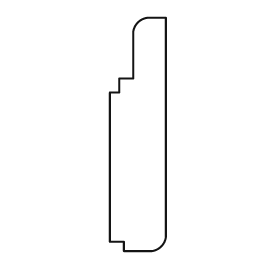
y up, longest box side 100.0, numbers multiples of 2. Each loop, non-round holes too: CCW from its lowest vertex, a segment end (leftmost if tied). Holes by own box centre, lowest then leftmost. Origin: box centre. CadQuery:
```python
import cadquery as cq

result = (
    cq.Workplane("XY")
    .moveTo(-6.0, -50.0)
    .lineTo(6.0, -50.0)
    .threePointArc((10.0, -48.0), (12.0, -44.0))
    .lineTo(12.0, 50.0)
    .lineTo(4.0, 50.0)
    .threePointArc((0.0, 48.0), (-2.0, 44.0))
    .lineTo(-2.0, 24.0)
    .lineTo(-8.0, 24.0)
    .lineTo(-8.0, 18.0)
    .lineTo(-12.0, 18.0)
    .lineTo(-12.0, -46.0)
    .lineTo(-6.0, -46.0)
    .close()
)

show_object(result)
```